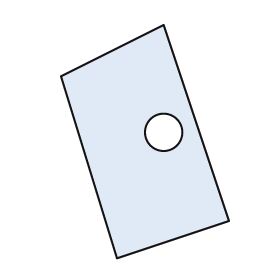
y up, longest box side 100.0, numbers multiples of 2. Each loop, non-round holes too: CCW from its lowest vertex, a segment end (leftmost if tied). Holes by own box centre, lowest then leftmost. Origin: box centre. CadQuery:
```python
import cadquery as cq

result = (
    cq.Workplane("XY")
    .moveTo(-12.0, -50.0)
    .lineTo(36.0, -34.0)
    .lineTo(8.0, 50.0)
    .lineTo(-36.0, 28.0)
    .close()
    .moveTo(8.0, 4.0)
    .circle(8.0)
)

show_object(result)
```